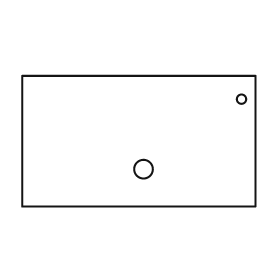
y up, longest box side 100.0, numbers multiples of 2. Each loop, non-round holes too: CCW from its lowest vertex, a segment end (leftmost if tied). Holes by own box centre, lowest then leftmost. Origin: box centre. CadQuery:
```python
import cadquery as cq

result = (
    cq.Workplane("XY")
    .moveTo(-50.0, -28.0)
    .lineTo(50.0, -28.0)
    .lineTo(50.0, 28.0)
    .lineTo(-50.0, 28.0)
    .close()
    .moveTo(2.0, -12.0)
    .circle(4.0)
    .moveTo(44.0, 18.0)
    .circle(2.0)
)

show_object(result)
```